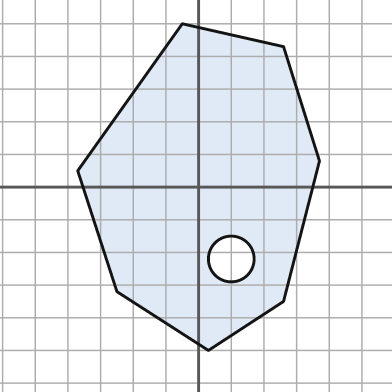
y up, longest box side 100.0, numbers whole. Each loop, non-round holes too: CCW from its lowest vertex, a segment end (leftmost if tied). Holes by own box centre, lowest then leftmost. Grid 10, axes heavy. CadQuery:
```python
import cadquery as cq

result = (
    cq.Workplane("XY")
    .moveTo(3.0, -50.0)
    .lineTo(26.0, -35.0)
    .lineTo(37.0, 8.0)
    .lineTo(26.0, 43.0)
    .lineTo(-5.0, 50.0)
    .lineTo(-37.0, 5.0)
    .lineTo(-25.0, -32.0)
    .close()
    .moveTo(10.0, -22.0)
    .circle(7.0)
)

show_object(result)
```